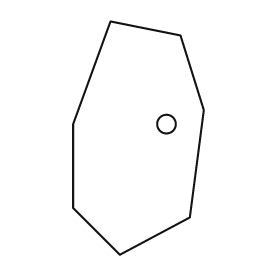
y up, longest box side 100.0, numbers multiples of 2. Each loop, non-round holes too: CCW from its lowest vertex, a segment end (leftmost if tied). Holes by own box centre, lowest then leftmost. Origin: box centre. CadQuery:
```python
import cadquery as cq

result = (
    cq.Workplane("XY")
    .moveTo(-8.0, -50.0)
    .lineTo(22.0, -34.0)
    .lineTo(28.0, 12.0)
    .lineTo(18.0, 44.0)
    .lineTo(-12.0, 50.0)
    .lineTo(-28.0, 6.0)
    .lineTo(-28.0, -30.0)
    .close()
    .moveTo(12.0, 6.0)
    .circle(4.0)
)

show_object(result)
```